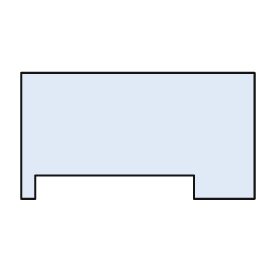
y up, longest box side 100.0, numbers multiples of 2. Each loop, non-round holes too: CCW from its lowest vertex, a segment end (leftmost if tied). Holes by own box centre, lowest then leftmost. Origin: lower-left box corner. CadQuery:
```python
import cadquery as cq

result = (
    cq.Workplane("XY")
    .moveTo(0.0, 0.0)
    .lineTo(6.0, 0.0)
    .lineTo(6.0, 10.0)
    .lineTo(74.0, 10.0)
    .lineTo(74.0, 0.0)
    .lineTo(100.0, 0.0)
    .lineTo(100.0, 54.0)
    .lineTo(0.0, 54.0)
    .close()
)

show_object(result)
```